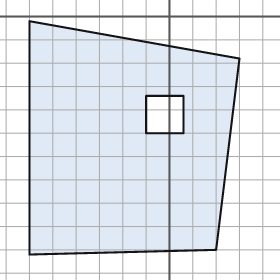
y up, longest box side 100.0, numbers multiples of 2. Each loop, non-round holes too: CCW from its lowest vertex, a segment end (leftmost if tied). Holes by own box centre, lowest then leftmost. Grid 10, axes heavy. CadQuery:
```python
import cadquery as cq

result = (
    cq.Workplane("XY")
    .moveTo(-60.0, -102.0)
    .lineTo(20.0, -100.0)
    .lineTo(30.0, -18.0)
    .lineTo(-60.0, -2.0)
    .close()
    .moveTo(-10.0, -50.0)
    .lineTo(6.0, -50.0)
    .lineTo(6.0, -34.0)
    .lineTo(-10.0, -34.0)
    .close()
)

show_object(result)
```